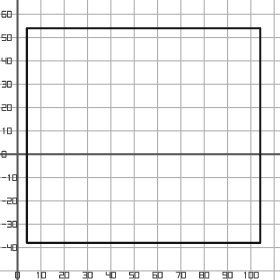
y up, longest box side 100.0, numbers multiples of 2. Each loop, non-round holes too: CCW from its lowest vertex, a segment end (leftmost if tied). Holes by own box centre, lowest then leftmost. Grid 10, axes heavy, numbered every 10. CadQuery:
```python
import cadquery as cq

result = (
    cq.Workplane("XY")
    .moveTo(4.0, -38.0)
    .lineTo(104.0, -38.0)
    .lineTo(104.0, 54.0)
    .lineTo(4.0, 54.0)
    .close()
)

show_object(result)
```